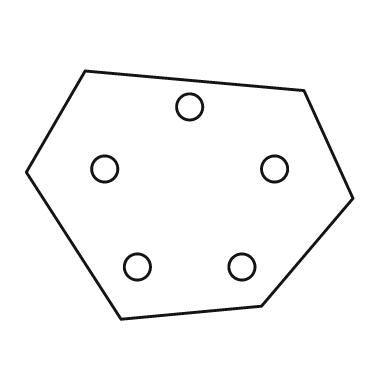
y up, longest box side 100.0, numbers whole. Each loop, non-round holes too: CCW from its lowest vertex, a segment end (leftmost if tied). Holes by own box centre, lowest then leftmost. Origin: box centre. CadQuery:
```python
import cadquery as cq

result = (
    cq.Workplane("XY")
    .moveTo(-21.0, -38.0)
    .lineTo(22.0, -34.0)
    .lineTo(50.0, -1.0)
    .lineTo(35.0, 32.0)
    .lineTo(-32.0, 38.0)
    .lineTo(-50.0, 7.0)
    .close()
    .moveTo(-16.0, -22.0)
    .circle(4.0)
    .moveTo(16.0, -22.0)
    .circle(4.0)
    .moveTo(-26.0, 8.0)
    .circle(4.0)
    .moveTo(26.0, 8.0)
    .circle(4.0)
    .moveTo(0.0, 27.0)
    .circle(4.0)
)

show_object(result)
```